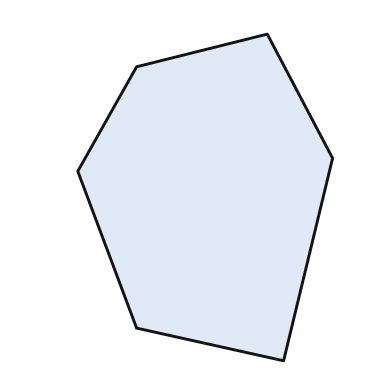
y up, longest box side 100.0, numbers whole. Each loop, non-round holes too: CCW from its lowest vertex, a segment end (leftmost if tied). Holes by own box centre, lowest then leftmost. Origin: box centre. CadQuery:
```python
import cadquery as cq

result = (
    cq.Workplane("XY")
    .moveTo(24.0, -50.0)
    .lineTo(39.0, 12.0)
    .lineTo(19.0, 50.0)
    .lineTo(-21.0, 40.0)
    .lineTo(-39.0, 8.0)
    .lineTo(-21.0, -40.0)
    .close()
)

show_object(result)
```